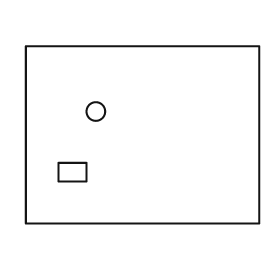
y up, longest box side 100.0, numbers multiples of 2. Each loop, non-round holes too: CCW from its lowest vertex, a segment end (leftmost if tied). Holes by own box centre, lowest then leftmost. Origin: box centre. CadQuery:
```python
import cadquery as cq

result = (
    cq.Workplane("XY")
    .moveTo(-50.0, -38.0)
    .lineTo(50.0, -38.0)
    .lineTo(50.0, 38.0)
    .lineTo(-50.0, 38.0)
    .close()
    .moveTo(-36.0, -20.0)
    .lineTo(-24.0, -20.0)
    .lineTo(-24.0, -12.0)
    .lineTo(-36.0, -12.0)
    .close()
    .moveTo(-20.0, 10.0)
    .circle(4.0)
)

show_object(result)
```